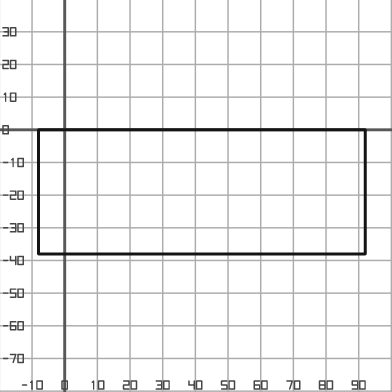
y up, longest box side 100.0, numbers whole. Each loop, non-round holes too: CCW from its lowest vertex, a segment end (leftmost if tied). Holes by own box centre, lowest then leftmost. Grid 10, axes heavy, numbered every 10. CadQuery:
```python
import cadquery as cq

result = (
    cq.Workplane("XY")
    .moveTo(-8.0, -38.0)
    .lineTo(92.0, -38.0)
    .lineTo(92.0, 0.0)
    .lineTo(-8.0, 0.0)
    .close()
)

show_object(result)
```